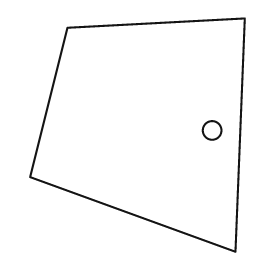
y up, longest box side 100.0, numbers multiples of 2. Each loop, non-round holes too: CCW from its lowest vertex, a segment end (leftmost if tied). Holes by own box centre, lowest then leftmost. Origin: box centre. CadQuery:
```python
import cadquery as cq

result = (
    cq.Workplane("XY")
    .moveTo(42.0, -50.0)
    .lineTo(46.0, 50.0)
    .lineTo(-30.0, 46.0)
    .lineTo(-46.0, -18.0)
    .close()
    .moveTo(32.0, 2.0)
    .circle(4.0)
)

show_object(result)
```